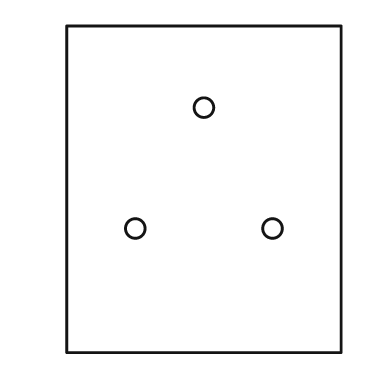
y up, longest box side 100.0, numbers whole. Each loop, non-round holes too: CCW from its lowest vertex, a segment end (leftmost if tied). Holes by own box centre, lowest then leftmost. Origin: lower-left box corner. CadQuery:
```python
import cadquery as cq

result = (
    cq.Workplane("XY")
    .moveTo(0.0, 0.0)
    .lineTo(84.0, 0.0)
    .lineTo(84.0, 100.0)
    .lineTo(0.0, 100.0)
    .close()
    .moveTo(21.0, 38.0)
    .circle(3.0)
    .moveTo(63.0, 38.0)
    .circle(3.0)
    .moveTo(42.0, 75.0)
    .circle(3.0)
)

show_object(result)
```